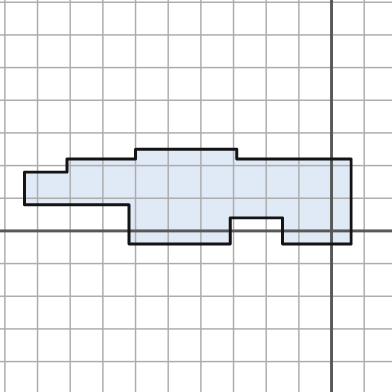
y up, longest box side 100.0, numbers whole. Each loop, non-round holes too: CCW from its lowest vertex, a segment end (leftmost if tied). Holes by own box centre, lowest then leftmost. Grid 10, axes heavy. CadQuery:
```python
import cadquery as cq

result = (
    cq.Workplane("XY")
    .moveTo(-62.0, -4.0)
    .lineTo(-31.0, -4.0)
    .lineTo(-31.0, 4.0)
    .lineTo(-15.0, 4.0)
    .lineTo(-15.0, -4.0)
    .lineTo(6.0, -4.0)
    .lineTo(6.0, 22.0)
    .lineTo(-29.0, 22.0)
    .lineTo(-29.0, 25.0)
    .lineTo(-60.0, 25.0)
    .lineTo(-60.0, 22.0)
    .lineTo(-81.0, 22.0)
    .lineTo(-81.0, 18.0)
    .lineTo(-94.0, 18.0)
    .lineTo(-94.0, 8.0)
    .lineTo(-62.0, 8.0)
    .close()
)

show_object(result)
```